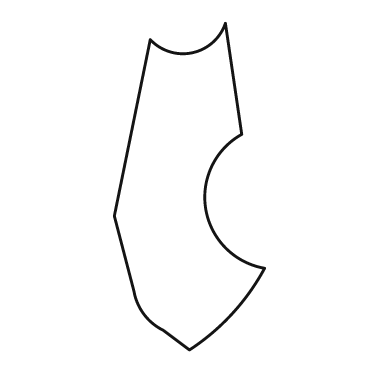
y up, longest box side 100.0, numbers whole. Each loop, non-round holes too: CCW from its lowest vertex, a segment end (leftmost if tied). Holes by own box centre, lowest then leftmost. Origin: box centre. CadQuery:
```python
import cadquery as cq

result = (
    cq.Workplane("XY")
    .moveTo(0.0, -50.0)
    .threePointArc((13.0, -39.0), (23.0, -25.0))
    .threePointArc((5.0, -7.0), (16.0, 16.0))
    .lineTo(11.0, 50.0)
    .threePointArc((1.0, 41.0), (-12.0, 45.0))
    .lineTo(-23.0, -9.0)
    .lineTo(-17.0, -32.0)
    .threePointArc((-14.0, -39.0), (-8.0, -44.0))
    .close()
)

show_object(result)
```